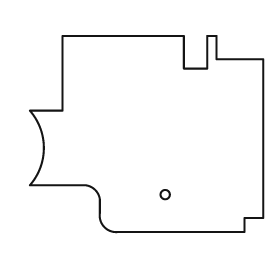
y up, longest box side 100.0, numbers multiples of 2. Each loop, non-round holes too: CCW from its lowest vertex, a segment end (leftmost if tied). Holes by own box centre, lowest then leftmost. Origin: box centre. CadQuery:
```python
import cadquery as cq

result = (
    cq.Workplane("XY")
    .moveTo(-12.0, -42.0)
    .lineTo(42.0, -42.0)
    .lineTo(42.0, -36.0)
    .lineTo(50.0, -36.0)
    .lineTo(50.0, 32.0)
    .lineTo(30.0, 32.0)
    .lineTo(30.0, 42.0)
    .lineTo(26.0, 42.0)
    .lineTo(26.0, 28.0)
    .lineTo(16.0, 28.0)
    .lineTo(16.0, 42.0)
    .lineTo(-36.0, 42.0)
    .lineTo(-36.0, 10.0)
    .lineTo(-50.0, 10.0)
    .threePointArc((-44.0, -6.0), (-50.0, -22.0))
    .lineTo(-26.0, -22.0)
    .threePointArc((-22.0, -24.0), (-20.0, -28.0))
    .lineTo(-20.0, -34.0)
    .threePointArc((-18.0, -40.0), (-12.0, -42.0))
    .close()
    .moveTo(8.0, -26.0)
    .circle(2.0)
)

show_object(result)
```